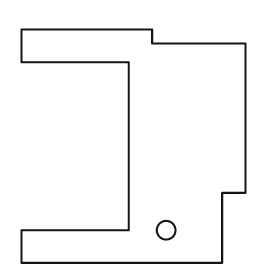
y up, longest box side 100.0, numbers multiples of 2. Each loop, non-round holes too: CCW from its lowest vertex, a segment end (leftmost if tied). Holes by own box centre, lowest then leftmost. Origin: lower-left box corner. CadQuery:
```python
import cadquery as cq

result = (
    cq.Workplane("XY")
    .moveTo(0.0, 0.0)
    .lineTo(86.0, 0.0)
    .lineTo(86.0, 30.0)
    .lineTo(96.0, 30.0)
    .lineTo(96.0, 94.0)
    .lineTo(56.0, 94.0)
    .lineTo(56.0, 100.0)
    .lineTo(0.0, 100.0)
    .lineTo(0.0, 86.0)
    .lineTo(46.0, 86.0)
    .lineTo(46.0, 14.0)
    .lineTo(0.0, 14.0)
    .close()
    .moveTo(62.0, 14.0)
    .circle(4.0)
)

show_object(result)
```